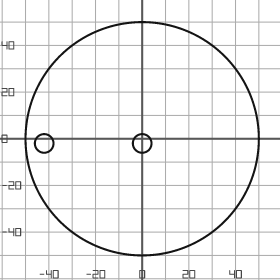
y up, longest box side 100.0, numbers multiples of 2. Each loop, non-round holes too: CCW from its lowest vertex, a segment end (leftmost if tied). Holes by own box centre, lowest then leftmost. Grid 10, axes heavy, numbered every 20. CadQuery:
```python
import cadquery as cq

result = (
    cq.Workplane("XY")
    .moveTo(0.0, 0.0)
    .circle(50.0)
    .moveTo(-42.0, -2.0)
    .circle(4.0)
    .moveTo(0.0, -2.0)
    .circle(4.0)
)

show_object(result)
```